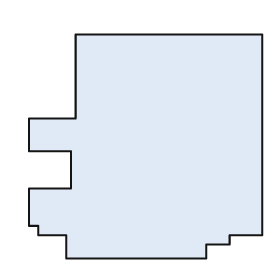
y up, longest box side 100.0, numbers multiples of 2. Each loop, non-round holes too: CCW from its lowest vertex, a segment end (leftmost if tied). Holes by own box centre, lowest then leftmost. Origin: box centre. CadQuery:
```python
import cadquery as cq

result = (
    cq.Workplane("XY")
    .moveTo(-34.0, -48.0)
    .lineTo(26.0, -48.0)
    .lineTo(26.0, -42.0)
    .lineTo(36.0, -42.0)
    .lineTo(36.0, -38.0)
    .lineTo(50.0, -38.0)
    .lineTo(50.0, 48.0)
    .lineTo(-30.0, 48.0)
    .lineTo(-30.0, 12.0)
    .lineTo(-50.0, 12.0)
    .lineTo(-50.0, -2.0)
    .lineTo(-32.0, -2.0)
    .lineTo(-32.0, -18.0)
    .lineTo(-50.0, -18.0)
    .lineTo(-50.0, -34.0)
    .lineTo(-46.0, -34.0)
    .lineTo(-46.0, -38.0)
    .lineTo(-34.0, -38.0)
    .close()
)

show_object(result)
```